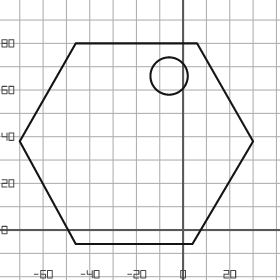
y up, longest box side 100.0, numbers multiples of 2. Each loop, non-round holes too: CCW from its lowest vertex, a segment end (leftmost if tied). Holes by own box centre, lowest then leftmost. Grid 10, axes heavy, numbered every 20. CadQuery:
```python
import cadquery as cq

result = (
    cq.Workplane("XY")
    .moveTo(-46.0, -6.0)
    .lineTo(4.0, -6.0)
    .lineTo(30.0, 38.0)
    .lineTo(6.0, 80.0)
    .lineTo(-46.0, 80.0)
    .lineTo(-70.0, 38.0)
    .close()
    .moveTo(-6.0, 66.0)
    .circle(8.0)
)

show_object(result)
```